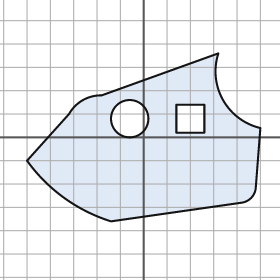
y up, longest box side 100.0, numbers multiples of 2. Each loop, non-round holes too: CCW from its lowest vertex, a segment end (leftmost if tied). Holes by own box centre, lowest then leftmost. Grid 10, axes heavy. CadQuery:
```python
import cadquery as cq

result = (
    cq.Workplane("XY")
    .moveTo(-14.0, -36.0)
    .lineTo(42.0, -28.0)
    .threePointArc((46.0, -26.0), (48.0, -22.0))
    .lineTo(50.0, 4.0)
    .threePointArc((34.0, 16.0), (32.0, 36.0))
    .lineTo(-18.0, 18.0)
    .threePointArc((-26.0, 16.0), (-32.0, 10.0))
    .lineTo(-50.0, -10.0)
    .threePointArc((-34.0, -26.0), (-14.0, -36.0))
    .close()
    .moveTo(-6.0, 8.0)
    .circle(8.0)
    .moveTo(14.0, 2.0)
    .lineTo(26.0, 2.0)
    .lineTo(26.0, 14.0)
    .lineTo(14.0, 14.0)
    .close()
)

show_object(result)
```